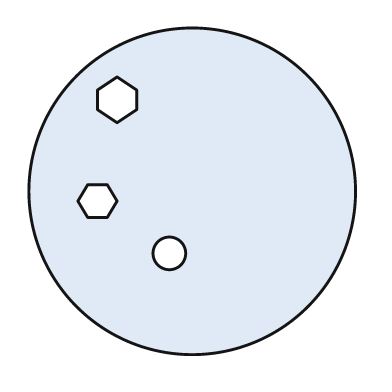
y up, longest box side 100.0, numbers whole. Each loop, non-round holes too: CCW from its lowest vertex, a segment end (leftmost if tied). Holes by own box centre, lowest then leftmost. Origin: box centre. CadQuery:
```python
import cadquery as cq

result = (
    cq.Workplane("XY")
    .moveTo(0.0, 0.0)
    .circle(50.0)
    .moveTo(-7.0, -19.0)
    .circle(5.0)
    .moveTo(-32.0, -8.0)
    .lineTo(-26.0, -8.0)
    .lineTo(-23.0, -3.0)
    .lineTo(-26.0, 2.0)
    .lineTo(-32.0, 2.0)
    .lineTo(-35.0, -3.0)
    .close()
    .moveTo(-23.0, 21.0)
    .lineTo(-17.0, 25.0)
    .lineTo(-17.0, 31.0)
    .lineTo(-23.0, 35.0)
    .lineTo(-29.0, 31.0)
    .lineTo(-29.0, 25.0)
    .close()
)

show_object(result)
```